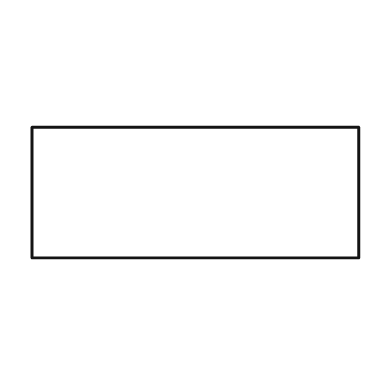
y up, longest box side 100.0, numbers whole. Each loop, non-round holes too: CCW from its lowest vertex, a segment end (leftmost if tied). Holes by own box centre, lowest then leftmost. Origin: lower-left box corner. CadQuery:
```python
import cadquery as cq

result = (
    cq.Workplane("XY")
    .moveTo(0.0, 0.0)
    .lineTo(100.0, 0.0)
    .lineTo(100.0, 40.0)
    .lineTo(0.0, 40.0)
    .close()
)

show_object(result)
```